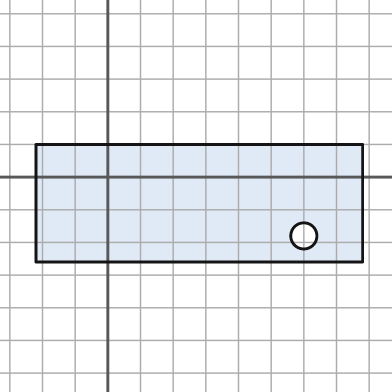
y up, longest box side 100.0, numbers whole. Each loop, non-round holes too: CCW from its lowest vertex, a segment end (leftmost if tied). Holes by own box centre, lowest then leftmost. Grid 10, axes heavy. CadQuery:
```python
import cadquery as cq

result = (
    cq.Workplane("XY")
    .moveTo(-22.0, -26.0)
    .lineTo(78.0, -26.0)
    .lineTo(78.0, 10.0)
    .lineTo(-22.0, 10.0)
    .close()
    .moveTo(60.0, -18.0)
    .circle(4.0)
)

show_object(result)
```